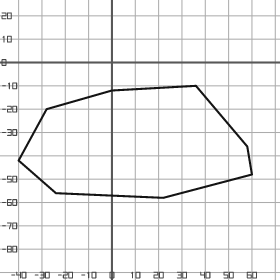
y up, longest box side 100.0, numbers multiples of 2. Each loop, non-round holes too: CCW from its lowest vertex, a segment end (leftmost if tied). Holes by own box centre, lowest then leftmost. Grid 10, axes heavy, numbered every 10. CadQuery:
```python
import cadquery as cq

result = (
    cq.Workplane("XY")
    .moveTo(22.0, -58.0)
    .lineTo(60.0, -48.0)
    .lineTo(58.0, -36.0)
    .lineTo(36.0, -10.0)
    .lineTo(0.0, -12.0)
    .lineTo(-28.0, -20.0)
    .lineTo(-40.0, -42.0)
    .lineTo(-24.0, -56.0)
    .close()
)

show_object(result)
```